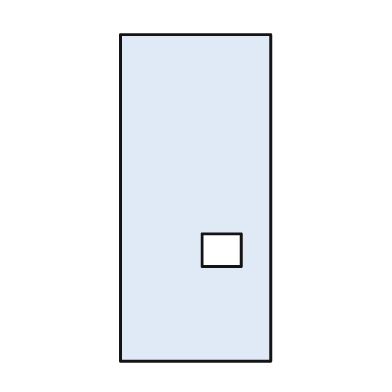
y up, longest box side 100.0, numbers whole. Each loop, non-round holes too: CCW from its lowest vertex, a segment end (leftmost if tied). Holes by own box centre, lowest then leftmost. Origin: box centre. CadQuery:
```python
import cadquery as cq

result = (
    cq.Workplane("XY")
    .moveTo(-23.0, -50.0)
    .lineTo(23.0, -50.0)
    .lineTo(23.0, 50.0)
    .lineTo(-23.0, 50.0)
    .close()
    .moveTo(2.0, -21.0)
    .lineTo(14.0, -21.0)
    .lineTo(14.0, -11.0)
    .lineTo(2.0, -11.0)
    .close()
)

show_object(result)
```